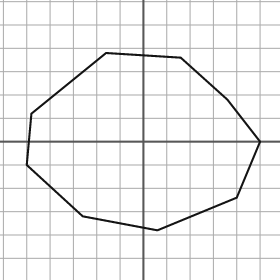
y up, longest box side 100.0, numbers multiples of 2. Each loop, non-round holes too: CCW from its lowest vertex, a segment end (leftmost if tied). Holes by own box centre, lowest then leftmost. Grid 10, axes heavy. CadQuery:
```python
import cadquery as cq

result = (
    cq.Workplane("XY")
    .moveTo(6.0, -38.0)
    .lineTo(40.0, -24.0)
    .lineTo(50.0, 0.0)
    .lineTo(36.0, 18.0)
    .lineTo(16.0, 36.0)
    .lineTo(-16.0, 38.0)
    .lineTo(-48.0, 12.0)
    .lineTo(-50.0, -10.0)
    .lineTo(-26.0, -32.0)
    .close()
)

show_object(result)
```